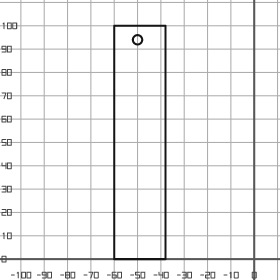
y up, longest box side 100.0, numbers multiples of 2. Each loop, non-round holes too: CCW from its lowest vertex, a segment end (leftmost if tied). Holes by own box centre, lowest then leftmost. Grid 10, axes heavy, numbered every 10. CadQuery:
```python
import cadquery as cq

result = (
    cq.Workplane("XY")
    .moveTo(-60.0, 0.0)
    .lineTo(-38.0, 0.0)
    .lineTo(-38.0, 100.0)
    .lineTo(-60.0, 100.0)
    .close()
    .moveTo(-50.0, 94.0)
    .circle(2.0)
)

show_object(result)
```